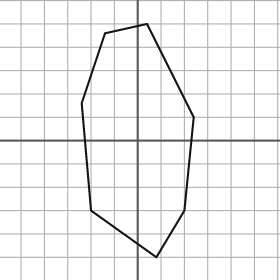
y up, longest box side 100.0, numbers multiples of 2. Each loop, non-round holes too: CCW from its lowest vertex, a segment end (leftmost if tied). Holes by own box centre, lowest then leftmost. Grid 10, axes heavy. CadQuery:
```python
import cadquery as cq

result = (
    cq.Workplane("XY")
    .moveTo(8.0, -50.0)
    .lineTo(20.0, -30.0)
    .lineTo(24.0, 10.0)
    .lineTo(4.0, 50.0)
    .lineTo(-14.0, 46.0)
    .lineTo(-24.0, 16.0)
    .lineTo(-20.0, -30.0)
    .close()
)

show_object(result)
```